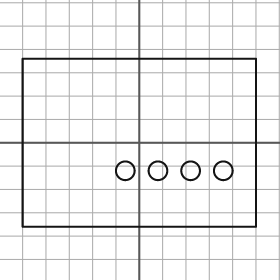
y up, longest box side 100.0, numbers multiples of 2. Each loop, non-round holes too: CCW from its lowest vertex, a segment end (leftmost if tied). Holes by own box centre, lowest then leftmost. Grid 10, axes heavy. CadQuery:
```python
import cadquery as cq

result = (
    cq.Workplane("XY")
    .moveTo(-50.0, -36.0)
    .lineTo(50.0, -36.0)
    .lineTo(50.0, 36.0)
    .lineTo(-50.0, 36.0)
    .close()
    .moveTo(-6.0, -12.0)
    .circle(4.0)
    .moveTo(8.0, -12.0)
    .circle(4.0)
    .moveTo(22.0, -12.0)
    .circle(4.0)
    .moveTo(36.0, -12.0)
    .circle(4.0)
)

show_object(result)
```